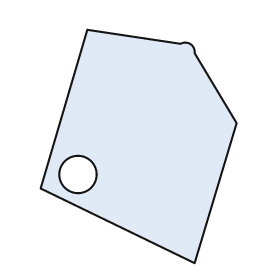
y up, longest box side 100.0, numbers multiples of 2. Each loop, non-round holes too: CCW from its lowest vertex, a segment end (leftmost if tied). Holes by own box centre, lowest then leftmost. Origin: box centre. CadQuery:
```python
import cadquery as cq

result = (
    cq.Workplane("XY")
    .moveTo(24.0, -50.0)
    .lineTo(42.0, 10.0)
    .lineTo(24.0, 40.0)
    .threePointArc((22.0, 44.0), (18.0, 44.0))
    .lineTo(-22.0, 50.0)
    .lineTo(-42.0, -18.0)
    .close()
    .moveTo(-26.0, -12.0)
    .circle(8.0)
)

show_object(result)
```